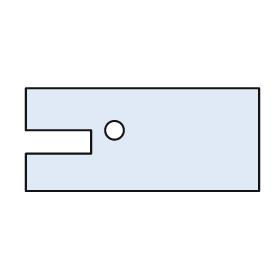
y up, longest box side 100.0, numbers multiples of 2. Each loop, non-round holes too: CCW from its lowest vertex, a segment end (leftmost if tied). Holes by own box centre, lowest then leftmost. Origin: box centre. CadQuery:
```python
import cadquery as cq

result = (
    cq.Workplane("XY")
    .moveTo(-50.0, -22.0)
    .lineTo(50.0, -22.0)
    .lineTo(50.0, 22.0)
    .lineTo(-50.0, 22.0)
    .lineTo(-50.0, 4.0)
    .lineTo(-22.0, 4.0)
    .lineTo(-22.0, -6.0)
    .lineTo(-50.0, -6.0)
    .close()
    .moveTo(-12.0, 4.0)
    .circle(4.0)
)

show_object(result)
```